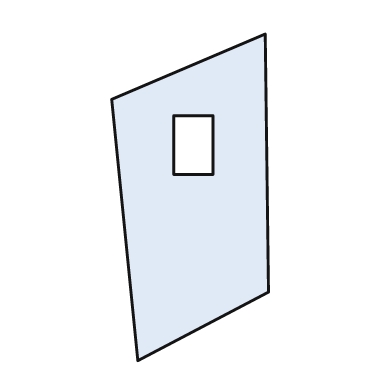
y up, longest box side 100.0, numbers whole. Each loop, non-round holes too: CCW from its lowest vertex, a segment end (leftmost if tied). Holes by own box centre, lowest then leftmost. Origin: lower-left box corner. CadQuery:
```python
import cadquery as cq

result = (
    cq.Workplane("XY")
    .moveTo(8.0, 0.0)
    .lineTo(48.0, 21.0)
    .lineTo(47.0, 100.0)
    .lineTo(0.0, 80.0)
    .close()
    .moveTo(19.0, 57.0)
    .lineTo(31.0, 57.0)
    .lineTo(31.0, 75.0)
    .lineTo(19.0, 75.0)
    .close()
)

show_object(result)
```